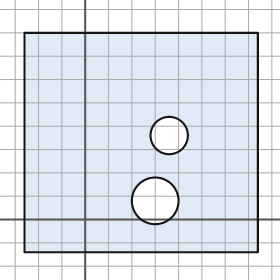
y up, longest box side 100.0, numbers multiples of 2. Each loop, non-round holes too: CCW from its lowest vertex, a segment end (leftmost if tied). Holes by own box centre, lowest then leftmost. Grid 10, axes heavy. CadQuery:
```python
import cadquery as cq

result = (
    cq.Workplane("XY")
    .moveTo(-26.0, -14.0)
    .lineTo(74.0, -14.0)
    .lineTo(74.0, 80.0)
    .lineTo(-26.0, 80.0)
    .close()
    .moveTo(30.0, 8.0)
    .circle(10.0)
    .moveTo(36.0, 36.0)
    .circle(8.0)
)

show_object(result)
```